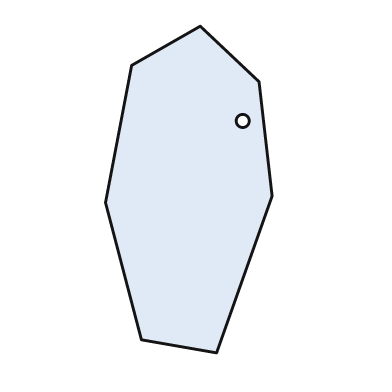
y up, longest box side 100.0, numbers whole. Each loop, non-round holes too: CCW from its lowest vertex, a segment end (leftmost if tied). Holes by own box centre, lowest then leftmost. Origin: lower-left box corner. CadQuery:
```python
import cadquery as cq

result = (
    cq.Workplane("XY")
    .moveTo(34.0, 0.0)
    .lineTo(51.0, 48.0)
    .lineTo(47.0, 83.0)
    .lineTo(29.0, 100.0)
    .lineTo(8.0, 88.0)
    .lineTo(0.0, 46.0)
    .lineTo(11.0, 4.0)
    .close()
    .moveTo(42.0, 71.0)
    .circle(2.0)
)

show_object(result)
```